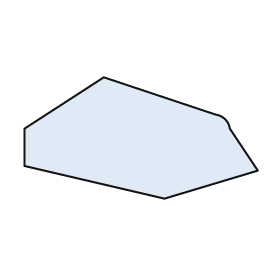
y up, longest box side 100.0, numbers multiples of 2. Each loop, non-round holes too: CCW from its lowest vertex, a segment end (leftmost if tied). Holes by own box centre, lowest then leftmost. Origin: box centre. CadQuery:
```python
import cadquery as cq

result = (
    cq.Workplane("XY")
    .moveTo(10.0, -26.0)
    .lineTo(50.0, -14.0)
    .lineTo(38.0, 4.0)
    .threePointArc((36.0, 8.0), (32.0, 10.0))
    .lineTo(-16.0, 26.0)
    .lineTo(-50.0, 4.0)
    .lineTo(-50.0, -12.0)
    .close()
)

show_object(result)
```